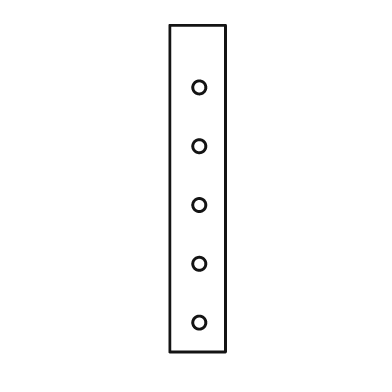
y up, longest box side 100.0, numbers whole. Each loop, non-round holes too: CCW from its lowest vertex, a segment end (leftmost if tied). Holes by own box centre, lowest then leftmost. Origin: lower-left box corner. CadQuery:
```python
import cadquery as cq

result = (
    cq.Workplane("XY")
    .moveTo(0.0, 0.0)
    .lineTo(17.0, 0.0)
    .lineTo(17.0, 100.0)
    .lineTo(0.0, 100.0)
    .close()
    .moveTo(9.0, 9.0)
    .circle(2.0)
    .moveTo(9.0, 27.0)
    .circle(2.0)
    .moveTo(9.0, 45.0)
    .circle(2.0)
    .moveTo(9.0, 63.0)
    .circle(2.0)
    .moveTo(9.0, 81.0)
    .circle(2.0)
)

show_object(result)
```